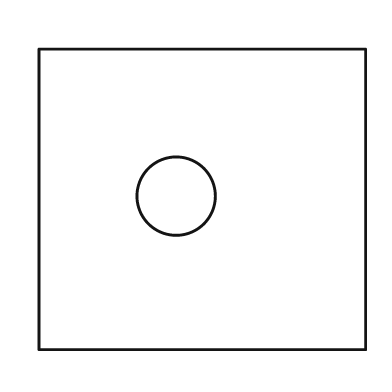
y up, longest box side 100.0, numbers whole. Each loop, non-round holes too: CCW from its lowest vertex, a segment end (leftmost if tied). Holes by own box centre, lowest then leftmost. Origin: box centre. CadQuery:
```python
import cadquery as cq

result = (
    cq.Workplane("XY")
    .moveTo(-50.0, -46.0)
    .lineTo(50.0, -46.0)
    .lineTo(50.0, 46.0)
    .lineTo(-50.0, 46.0)
    .close()
    .moveTo(-8.0, 1.0)
    .circle(12.0)
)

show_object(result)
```